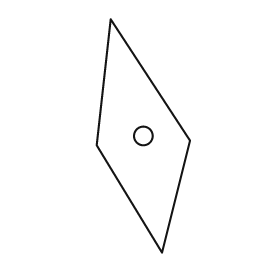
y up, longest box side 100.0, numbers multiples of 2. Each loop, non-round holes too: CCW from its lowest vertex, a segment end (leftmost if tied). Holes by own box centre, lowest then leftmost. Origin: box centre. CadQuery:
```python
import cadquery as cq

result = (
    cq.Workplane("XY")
    .moveTo(8.0, -50.0)
    .lineTo(20.0, -2.0)
    .lineTo(-14.0, 50.0)
    .lineTo(-20.0, -4.0)
    .close()
    .moveTo(0.0, 0.0)
    .circle(4.0)
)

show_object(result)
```